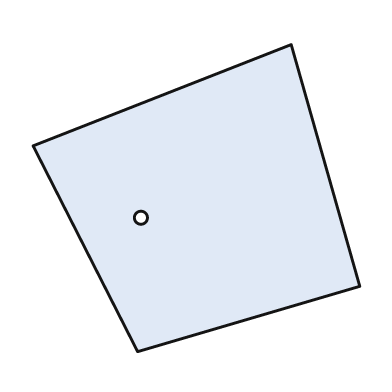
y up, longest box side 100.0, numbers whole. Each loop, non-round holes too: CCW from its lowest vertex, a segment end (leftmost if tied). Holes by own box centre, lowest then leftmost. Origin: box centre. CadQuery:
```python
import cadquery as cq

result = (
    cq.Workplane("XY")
    .moveTo(-18.0, -47.0)
    .lineTo(50.0, -27.0)
    .lineTo(29.0, 47.0)
    .lineTo(-50.0, 16.0)
    .close()
    .moveTo(-17.0, -6.0)
    .circle(2.0)
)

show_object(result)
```